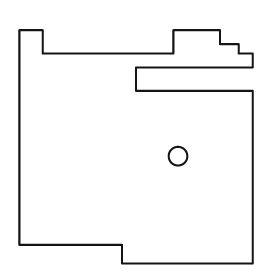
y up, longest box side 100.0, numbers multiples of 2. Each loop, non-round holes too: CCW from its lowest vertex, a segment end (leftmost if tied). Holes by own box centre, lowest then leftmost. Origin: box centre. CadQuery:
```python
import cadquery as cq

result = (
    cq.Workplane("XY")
    .moveTo(-6.0, -50.0)
    .lineTo(50.0, -50.0)
    .lineTo(50.0, 24.0)
    .lineTo(0.0, 24.0)
    .lineTo(0.0, 34.0)
    .lineTo(50.0, 34.0)
    .lineTo(50.0, 40.0)
    .lineTo(44.0, 40.0)
    .lineTo(44.0, 44.0)
    .lineTo(36.0, 44.0)
    .lineTo(36.0, 50.0)
    .lineTo(16.0, 50.0)
    .lineTo(16.0, 40.0)
    .lineTo(-40.0, 40.0)
    .lineTo(-40.0, 50.0)
    .lineTo(-50.0, 50.0)
    .lineTo(-50.0, -42.0)
    .lineTo(-6.0, -42.0)
    .close()
    .moveTo(18.0, -4.0)
    .circle(4.0)
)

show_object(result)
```